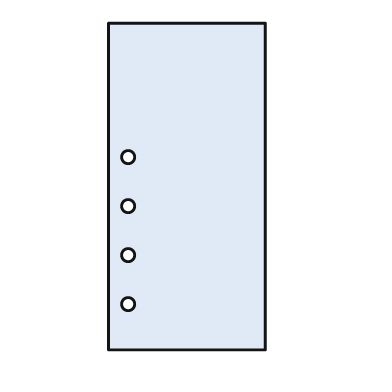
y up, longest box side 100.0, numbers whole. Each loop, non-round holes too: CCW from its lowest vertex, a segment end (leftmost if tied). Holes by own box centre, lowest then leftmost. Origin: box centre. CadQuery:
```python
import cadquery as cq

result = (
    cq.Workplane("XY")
    .moveTo(-24.0, -50.0)
    .lineTo(24.0, -50.0)
    .lineTo(24.0, 50.0)
    .lineTo(-24.0, 50.0)
    .close()
    .moveTo(-18.0, -36.0)
    .circle(2.0)
    .moveTo(-18.0, -21.0)
    .circle(2.0)
    .moveTo(-18.0, -6.0)
    .circle(2.0)
    .moveTo(-18.0, 9.0)
    .circle(2.0)
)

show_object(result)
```